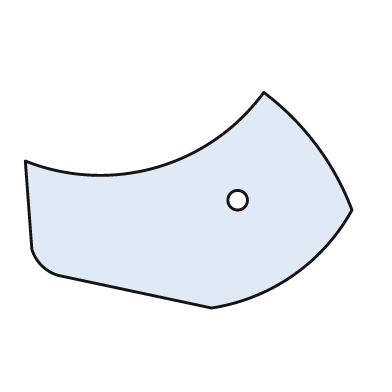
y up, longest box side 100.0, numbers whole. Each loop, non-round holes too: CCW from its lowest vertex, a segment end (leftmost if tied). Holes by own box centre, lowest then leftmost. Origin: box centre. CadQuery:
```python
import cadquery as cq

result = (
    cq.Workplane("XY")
    .moveTo(7.0, -33.0)
    .threePointArc((32.0, -23.0), (50.0, -3.0))
    .threePointArc((39.0, 17.0), (23.0, 33.0))
    .threePointArc((-10.0, 10.0), (-50.0, 12.0))
    .lineTo(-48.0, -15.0)
    .threePointArc((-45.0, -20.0), (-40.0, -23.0))
    .close()
    .moveTo(15.0, 0.0)
    .circle(3.0)
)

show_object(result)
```